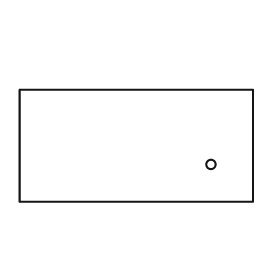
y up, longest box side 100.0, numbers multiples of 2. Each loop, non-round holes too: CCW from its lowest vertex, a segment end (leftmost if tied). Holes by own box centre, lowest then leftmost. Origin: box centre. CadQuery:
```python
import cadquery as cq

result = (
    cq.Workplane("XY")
    .moveTo(-50.0, -24.0)
    .lineTo(50.0, -24.0)
    .lineTo(50.0, 24.0)
    .lineTo(-50.0, 24.0)
    .close()
    .moveTo(32.0, -8.0)
    .circle(2.0)
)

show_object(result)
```